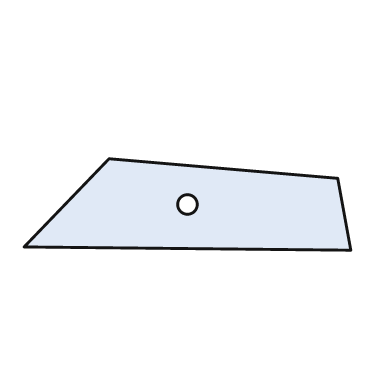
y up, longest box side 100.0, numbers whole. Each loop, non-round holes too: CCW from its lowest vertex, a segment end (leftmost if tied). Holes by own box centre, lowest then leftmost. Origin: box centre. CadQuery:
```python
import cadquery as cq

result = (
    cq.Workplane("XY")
    .moveTo(50.0, -14.0)
    .lineTo(46.0, 8.0)
    .lineTo(-24.0, 14.0)
    .lineTo(-50.0, -13.0)
    .close()
    .moveTo(0.0, 0.0)
    .circle(3.0)
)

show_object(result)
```